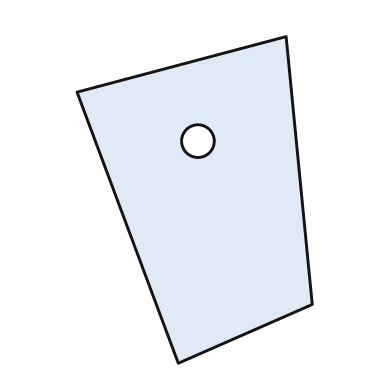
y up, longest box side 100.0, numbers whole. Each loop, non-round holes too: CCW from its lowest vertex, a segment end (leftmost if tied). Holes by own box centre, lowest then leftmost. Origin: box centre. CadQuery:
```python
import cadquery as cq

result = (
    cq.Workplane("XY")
    .moveTo(-5.0, -50.0)
    .lineTo(36.0, -32.0)
    .lineTo(28.0, 50.0)
    .lineTo(-36.0, 33.0)
    .close()
    .moveTo(1.0, 18.0)
    .circle(5.0)
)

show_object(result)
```